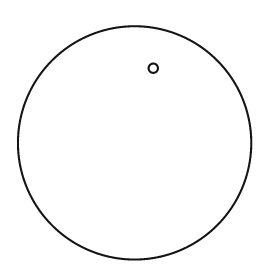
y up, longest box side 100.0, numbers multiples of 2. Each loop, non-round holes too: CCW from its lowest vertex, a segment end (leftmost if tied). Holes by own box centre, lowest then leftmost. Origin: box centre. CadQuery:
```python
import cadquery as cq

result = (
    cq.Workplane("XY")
    .moveTo(0.0, 0.0)
    .circle(50.0)
    .moveTo(8.0, 32.0)
    .circle(2.0)
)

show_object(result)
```